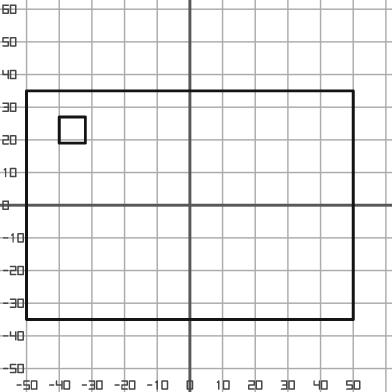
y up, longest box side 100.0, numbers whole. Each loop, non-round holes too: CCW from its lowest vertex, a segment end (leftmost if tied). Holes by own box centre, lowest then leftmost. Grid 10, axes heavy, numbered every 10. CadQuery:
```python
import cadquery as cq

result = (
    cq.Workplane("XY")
    .moveTo(-50.0, -35.0)
    .lineTo(50.0, -35.0)
    .lineTo(50.0, 35.0)
    .lineTo(-50.0, 35.0)
    .close()
    .moveTo(-40.0, 19.0)
    .lineTo(-32.0, 19.0)
    .lineTo(-32.0, 27.0)
    .lineTo(-40.0, 27.0)
    .close()
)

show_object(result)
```